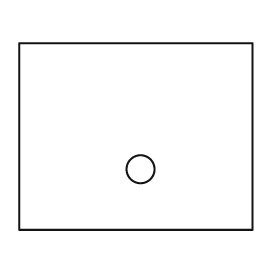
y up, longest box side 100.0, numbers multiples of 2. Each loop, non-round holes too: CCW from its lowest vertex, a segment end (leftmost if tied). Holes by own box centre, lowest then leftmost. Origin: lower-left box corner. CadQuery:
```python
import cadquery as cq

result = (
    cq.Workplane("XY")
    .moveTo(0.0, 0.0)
    .lineTo(100.0, 0.0)
    .lineTo(100.0, 80.0)
    .lineTo(0.0, 80.0)
    .close()
    .moveTo(52.0, 26.0)
    .circle(6.0)
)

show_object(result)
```